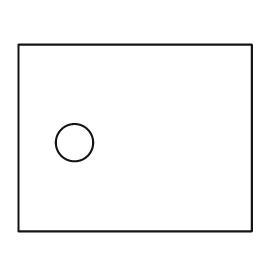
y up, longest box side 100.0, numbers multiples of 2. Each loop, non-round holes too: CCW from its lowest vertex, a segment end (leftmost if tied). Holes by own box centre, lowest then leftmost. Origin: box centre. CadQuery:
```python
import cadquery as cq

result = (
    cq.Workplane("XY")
    .moveTo(-50.0, -40.0)
    .lineTo(50.0, -40.0)
    .lineTo(50.0, 40.0)
    .lineTo(-50.0, 40.0)
    .close()
    .moveTo(-26.0, -2.0)
    .circle(8.0)
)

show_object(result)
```